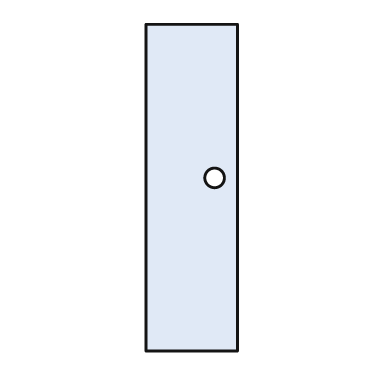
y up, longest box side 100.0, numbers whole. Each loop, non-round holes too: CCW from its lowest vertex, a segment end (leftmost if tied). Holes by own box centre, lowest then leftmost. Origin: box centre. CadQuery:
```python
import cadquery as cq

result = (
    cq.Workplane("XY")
    .moveTo(-14.0, -50.0)
    .lineTo(14.0, -50.0)
    .lineTo(14.0, 50.0)
    .lineTo(-14.0, 50.0)
    .close()
    .moveTo(7.0, 3.0)
    .circle(3.0)
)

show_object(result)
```